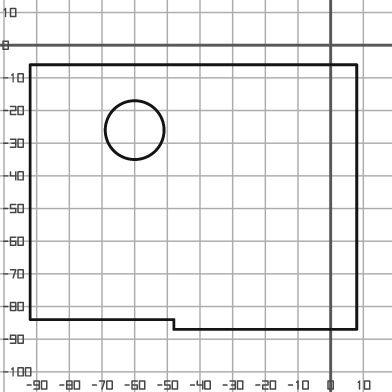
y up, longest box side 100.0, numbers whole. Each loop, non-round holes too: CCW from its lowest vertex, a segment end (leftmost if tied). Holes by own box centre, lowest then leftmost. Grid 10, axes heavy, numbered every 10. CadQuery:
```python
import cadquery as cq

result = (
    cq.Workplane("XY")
    .moveTo(-48.0, -87.0)
    .lineTo(8.0, -87.0)
    .lineTo(8.0, -6.0)
    .lineTo(-92.0, -6.0)
    .lineTo(-92.0, -84.0)
    .lineTo(-48.0, -84.0)
    .close()
    .moveTo(-60.0, -26.0)
    .circle(9.0)
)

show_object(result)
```